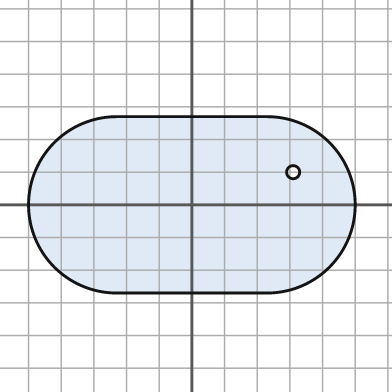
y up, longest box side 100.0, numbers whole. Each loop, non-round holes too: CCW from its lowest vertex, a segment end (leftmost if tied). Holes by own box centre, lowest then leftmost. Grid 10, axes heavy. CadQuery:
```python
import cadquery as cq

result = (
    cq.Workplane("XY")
    .moveTo(-23.0, -27.0)
    .lineTo(23.0, -27.0)
    .threePointArc((50.0, 0.0), (23.0, 27.0))
    .lineTo(-23.0, 27.0)
    .threePointArc((-50.0, 0.0), (-23.0, -27.0))
    .close()
    .moveTo(31.0, 10.0)
    .circle(2.0)
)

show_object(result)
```